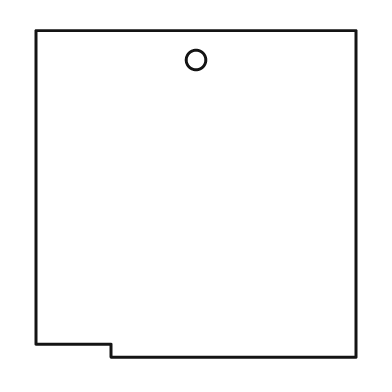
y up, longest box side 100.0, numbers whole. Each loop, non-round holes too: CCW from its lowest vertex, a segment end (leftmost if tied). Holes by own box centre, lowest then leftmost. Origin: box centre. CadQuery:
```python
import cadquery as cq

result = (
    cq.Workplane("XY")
    .moveTo(-26.0, -50.0)
    .lineTo(49.0, -50.0)
    .lineTo(49.0, 50.0)
    .lineTo(-49.0, 50.0)
    .lineTo(-49.0, -46.0)
    .lineTo(-26.0, -46.0)
    .close()
    .moveTo(0.0, 41.0)
    .circle(3.0)
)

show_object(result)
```